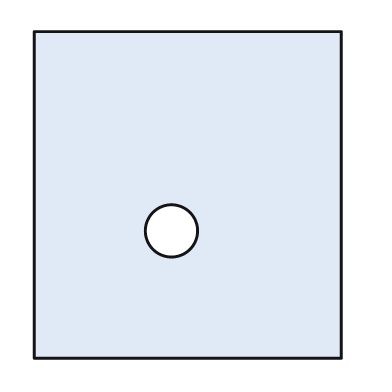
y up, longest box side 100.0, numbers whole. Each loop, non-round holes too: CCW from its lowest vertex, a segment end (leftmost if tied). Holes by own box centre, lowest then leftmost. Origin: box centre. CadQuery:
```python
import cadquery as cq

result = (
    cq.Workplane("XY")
    .moveTo(-47.0, -50.0)
    .lineTo(47.0, -50.0)
    .lineTo(47.0, 50.0)
    .lineTo(-47.0, 50.0)
    .close()
    .moveTo(-5.0, -11.0)
    .circle(8.0)
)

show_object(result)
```